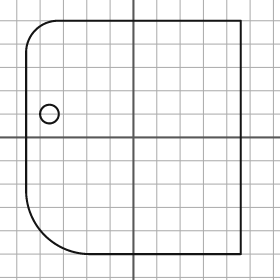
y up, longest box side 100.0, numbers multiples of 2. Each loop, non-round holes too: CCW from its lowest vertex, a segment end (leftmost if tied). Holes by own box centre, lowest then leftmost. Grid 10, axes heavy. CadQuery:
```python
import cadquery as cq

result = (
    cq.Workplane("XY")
    .moveTo(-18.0, -50.0)
    .lineTo(46.0, -50.0)
    .lineTo(46.0, 50.0)
    .lineTo(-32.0, 50.0)
    .threePointArc((-42.0, 46.0), (-46.0, 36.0))
    .lineTo(-46.0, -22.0)
    .threePointArc((-38.0, -42.0), (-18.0, -50.0))
    .close()
    .moveTo(-36.0, 10.0)
    .circle(4.0)
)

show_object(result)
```